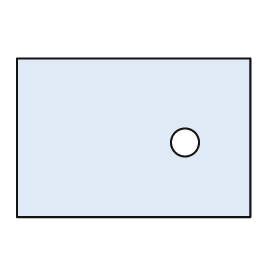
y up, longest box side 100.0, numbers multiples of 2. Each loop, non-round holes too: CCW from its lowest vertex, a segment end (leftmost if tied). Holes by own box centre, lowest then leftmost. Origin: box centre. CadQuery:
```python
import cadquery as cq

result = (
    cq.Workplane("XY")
    .moveTo(-50.0, -34.0)
    .lineTo(50.0, -34.0)
    .lineTo(50.0, 34.0)
    .lineTo(-50.0, 34.0)
    .close()
    .moveTo(22.0, -2.0)
    .circle(6.0)
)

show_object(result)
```